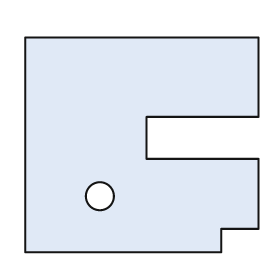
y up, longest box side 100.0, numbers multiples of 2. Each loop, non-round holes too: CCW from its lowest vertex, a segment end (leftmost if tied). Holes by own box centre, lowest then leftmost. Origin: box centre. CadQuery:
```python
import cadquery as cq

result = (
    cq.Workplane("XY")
    .moveTo(-50.0, -46.0)
    .lineTo(34.0, -46.0)
    .lineTo(34.0, -36.0)
    .lineTo(50.0, -36.0)
    .lineTo(50.0, -6.0)
    .lineTo(2.0, -6.0)
    .lineTo(2.0, 12.0)
    .lineTo(50.0, 12.0)
    .lineTo(50.0, 46.0)
    .lineTo(-50.0, 46.0)
    .close()
    .moveTo(-18.0, -22.0)
    .circle(6.0)
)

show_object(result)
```